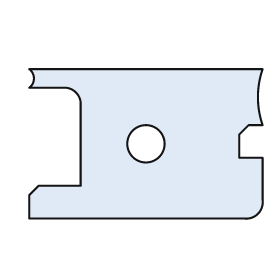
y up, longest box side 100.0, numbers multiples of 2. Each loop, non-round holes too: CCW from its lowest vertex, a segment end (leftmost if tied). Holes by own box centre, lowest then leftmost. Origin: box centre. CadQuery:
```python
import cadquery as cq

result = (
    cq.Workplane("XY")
    .moveTo(-50.0, -32.0)
    .lineTo(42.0, -32.0)
    .threePointArc((48.0, -30.0), (50.0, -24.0))
    .lineTo(50.0, -6.0)
    .lineTo(40.0, -6.0)
    .lineTo(40.0, 4.0)
    .lineTo(44.0, 8.0)
    .lineTo(50.0, 8.0)
    .threePointArc((48.0, 20.0), (50.0, 32.0))
    .lineTo(-50.0, 32.0)
    .threePointArc((-48.0, 28.0), (-50.0, 24.0))
    .lineTo(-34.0, 24.0)
    .threePointArc((-30.0, 22.0), (-28.0, 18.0))
    .lineTo(-28.0, -18.0)
    .lineTo(-46.0, -18.0)
    .lineTo(-50.0, -22.0)
    .close()
    .moveTo(0.0, 0.0)
    .circle(8.0)
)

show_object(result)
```